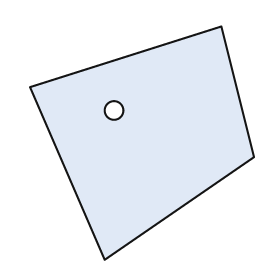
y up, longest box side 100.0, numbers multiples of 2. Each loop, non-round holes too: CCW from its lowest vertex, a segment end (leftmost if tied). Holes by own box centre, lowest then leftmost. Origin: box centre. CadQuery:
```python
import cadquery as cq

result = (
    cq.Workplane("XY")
    .moveTo(-16.0, -50.0)
    .lineTo(48.0, -6.0)
    .lineTo(34.0, 50.0)
    .lineTo(-48.0, 24.0)
    .close()
    .moveTo(-12.0, 14.0)
    .circle(4.0)
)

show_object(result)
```